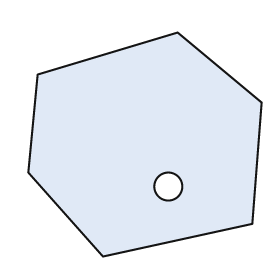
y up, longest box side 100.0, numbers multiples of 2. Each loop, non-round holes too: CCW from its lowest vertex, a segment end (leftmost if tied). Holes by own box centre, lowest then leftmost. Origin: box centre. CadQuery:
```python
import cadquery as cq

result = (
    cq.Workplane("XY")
    .moveTo(-18.0, -48.0)
    .lineTo(46.0, -34.0)
    .lineTo(50.0, 18.0)
    .lineTo(14.0, 48.0)
    .lineTo(-46.0, 30.0)
    .lineTo(-50.0, -12.0)
    .close()
    .moveTo(10.0, -18.0)
    .circle(6.0)
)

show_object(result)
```